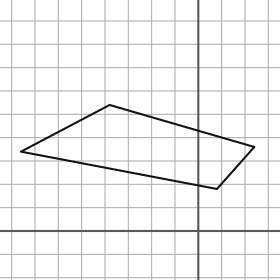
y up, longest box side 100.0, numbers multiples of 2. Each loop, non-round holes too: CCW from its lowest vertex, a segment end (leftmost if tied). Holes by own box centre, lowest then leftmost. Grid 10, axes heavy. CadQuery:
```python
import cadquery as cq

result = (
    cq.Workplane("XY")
    .moveTo(8.0, 18.0)
    .lineTo(24.0, 36.0)
    .lineTo(-38.0, 54.0)
    .lineTo(-76.0, 34.0)
    .close()
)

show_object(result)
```